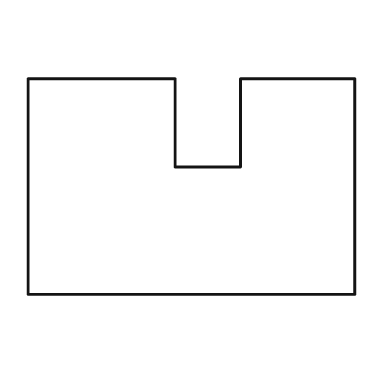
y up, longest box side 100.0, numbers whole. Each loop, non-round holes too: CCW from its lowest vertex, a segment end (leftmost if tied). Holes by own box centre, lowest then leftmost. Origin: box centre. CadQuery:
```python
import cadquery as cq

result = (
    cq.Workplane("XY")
    .moveTo(-50.0, -33.0)
    .lineTo(50.0, -33.0)
    .lineTo(50.0, 33.0)
    .lineTo(15.0, 33.0)
    .lineTo(15.0, 6.0)
    .lineTo(-5.0, 6.0)
    .lineTo(-5.0, 33.0)
    .lineTo(-50.0, 33.0)
    .close()
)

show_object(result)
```